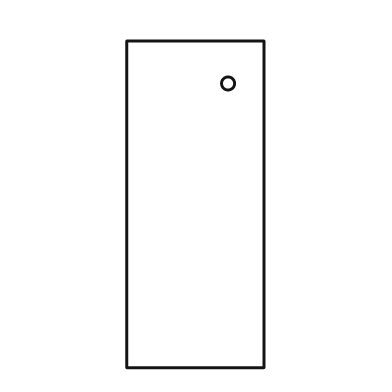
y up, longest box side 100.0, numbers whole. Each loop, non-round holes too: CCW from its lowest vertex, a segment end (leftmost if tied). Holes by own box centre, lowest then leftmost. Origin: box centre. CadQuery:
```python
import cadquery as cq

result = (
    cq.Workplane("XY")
    .moveTo(-21.0, -50.0)
    .lineTo(21.0, -50.0)
    .lineTo(21.0, 50.0)
    .lineTo(-21.0, 50.0)
    .close()
    .moveTo(10.0, 37.0)
    .circle(2.0)
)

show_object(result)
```